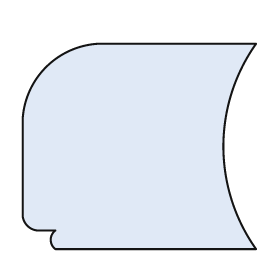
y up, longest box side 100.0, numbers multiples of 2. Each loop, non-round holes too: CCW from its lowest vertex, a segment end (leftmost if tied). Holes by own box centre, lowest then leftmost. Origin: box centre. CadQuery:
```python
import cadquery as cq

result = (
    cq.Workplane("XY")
    .moveTo(-36.0, -44.0)
    .lineTo(50.0, -44.0)
    .threePointArc((36.0, 0.0), (50.0, 44.0))
    .lineTo(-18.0, 44.0)
    .threePointArc((-40.0, 34.0), (-50.0, 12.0))
    .lineTo(-50.0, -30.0)
    .threePointArc((-48.0, -34.0), (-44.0, -36.0))
    .lineTo(-36.0, -36.0)
    .threePointArc((-38.0, -40.0), (-36.0, -44.0))
    .close()
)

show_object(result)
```